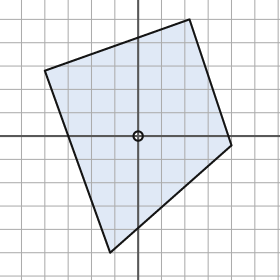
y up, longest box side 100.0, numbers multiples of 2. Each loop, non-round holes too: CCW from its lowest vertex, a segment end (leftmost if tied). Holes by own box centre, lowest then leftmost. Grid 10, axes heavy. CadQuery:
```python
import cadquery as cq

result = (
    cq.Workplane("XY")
    .moveTo(-12.0, -50.0)
    .lineTo(40.0, -4.0)
    .lineTo(22.0, 50.0)
    .lineTo(-40.0, 28.0)
    .close()
    .moveTo(0.0, 0.0)
    .circle(2.0)
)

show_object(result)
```